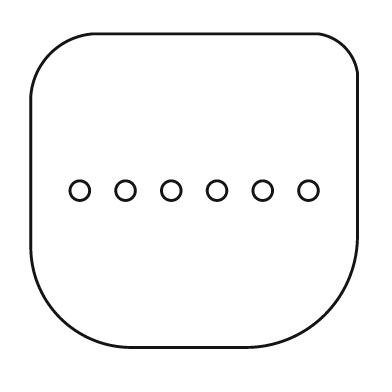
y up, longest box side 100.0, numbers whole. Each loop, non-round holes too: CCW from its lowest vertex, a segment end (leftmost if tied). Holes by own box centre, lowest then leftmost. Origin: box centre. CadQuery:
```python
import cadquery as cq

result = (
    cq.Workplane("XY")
    .moveTo(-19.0, -48.0)
    .lineTo(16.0, -48.0)
    .threePointArc((40.0, -38.0), (50.0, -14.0))
    .lineTo(50.0, 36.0)
    .threePointArc((46.0, 44.0), (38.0, 48.0))
    .lineTo(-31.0, 48.0)
    .threePointArc((-44.0, 42.0), (-50.0, 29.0))
    .lineTo(-50.0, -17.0)
    .threePointArc((-41.0, -39.0), (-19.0, -48.0))
    .close()
    .moveTo(-35.0, 0.0)
    .circle(3.0)
    .moveTo(-21.0, 0.0)
    .circle(3.0)
    .moveTo(-7.0, 0.0)
    .circle(3.0)
    .moveTo(7.0, 0.0)
    .circle(3.0)
    .moveTo(21.0, 0.0)
    .circle(3.0)
    .moveTo(35.0, 0.0)
    .circle(3.0)
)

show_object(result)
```